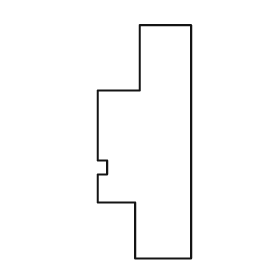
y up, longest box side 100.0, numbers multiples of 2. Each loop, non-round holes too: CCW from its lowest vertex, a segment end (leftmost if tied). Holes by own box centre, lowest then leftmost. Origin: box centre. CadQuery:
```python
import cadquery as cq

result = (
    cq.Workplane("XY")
    .moveTo(-4.0, -50.0)
    .lineTo(20.0, -50.0)
    .lineTo(20.0, 50.0)
    .lineTo(-2.0, 50.0)
    .lineTo(-2.0, 22.0)
    .lineTo(-20.0, 22.0)
    .lineTo(-20.0, -8.0)
    .lineTo(-16.0, -8.0)
    .lineTo(-16.0, -14.0)
    .lineTo(-20.0, -14.0)
    .lineTo(-20.0, -26.0)
    .lineTo(-4.0, -26.0)
    .close()
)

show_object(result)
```